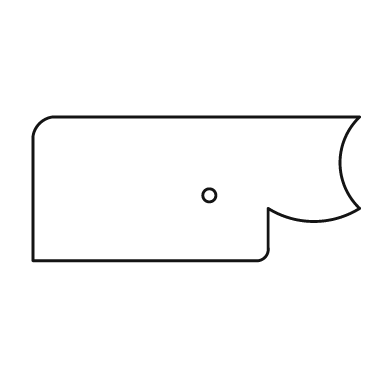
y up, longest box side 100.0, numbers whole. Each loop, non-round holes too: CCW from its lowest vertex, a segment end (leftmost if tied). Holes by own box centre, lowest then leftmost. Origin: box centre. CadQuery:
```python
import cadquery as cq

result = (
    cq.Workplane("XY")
    .moveTo(-50.0, -22.0)
    .lineTo(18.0, -22.0)
    .threePointArc((21.0, -21.0), (22.0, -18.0))
    .lineTo(22.0, -6.0)
    .threePointArc((36.0, -10.0), (50.0, -6.0))
    .threePointArc((44.0, 8.0), (50.0, 22.0))
    .lineTo(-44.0, 22.0)
    .threePointArc((-48.0, 20.0), (-50.0, 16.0))
    .close()
    .moveTo(4.0, -2.0)
    .circle(2.0)
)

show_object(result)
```